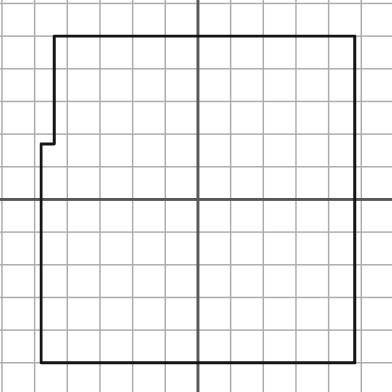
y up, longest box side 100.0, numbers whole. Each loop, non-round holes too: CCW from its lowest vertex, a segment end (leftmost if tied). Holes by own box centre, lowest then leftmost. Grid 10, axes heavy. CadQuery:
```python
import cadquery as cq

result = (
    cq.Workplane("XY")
    .moveTo(-48.0, -50.0)
    .lineTo(48.0, -50.0)
    .lineTo(48.0, 50.0)
    .lineTo(-44.0, 50.0)
    .lineTo(-44.0, 17.0)
    .lineTo(-48.0, 17.0)
    .close()
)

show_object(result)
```